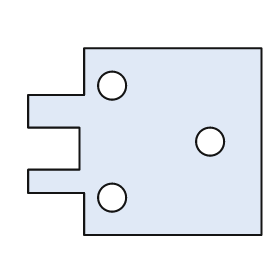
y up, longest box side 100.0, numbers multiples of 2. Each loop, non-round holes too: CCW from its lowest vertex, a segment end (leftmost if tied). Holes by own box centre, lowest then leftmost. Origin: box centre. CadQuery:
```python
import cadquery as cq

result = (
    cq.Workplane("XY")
    .moveTo(-26.0, -40.0)
    .lineTo(50.0, -40.0)
    .lineTo(50.0, 40.0)
    .lineTo(-26.0, 40.0)
    .lineTo(-26.0, 20.0)
    .lineTo(-50.0, 20.0)
    .lineTo(-50.0, 6.0)
    .lineTo(-28.0, 6.0)
    .lineTo(-28.0, -12.0)
    .lineTo(-50.0, -12.0)
    .lineTo(-50.0, -22.0)
    .lineTo(-26.0, -22.0)
    .close()
    .moveTo(-14.0, -24.0)
    .circle(6.0)
    .moveTo(28.0, 0.0)
    .circle(6.0)
    .moveTo(-14.0, 24.0)
    .circle(6.0)
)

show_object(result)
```